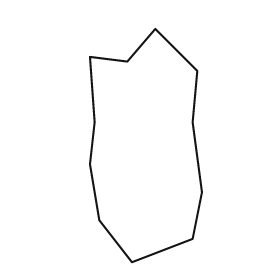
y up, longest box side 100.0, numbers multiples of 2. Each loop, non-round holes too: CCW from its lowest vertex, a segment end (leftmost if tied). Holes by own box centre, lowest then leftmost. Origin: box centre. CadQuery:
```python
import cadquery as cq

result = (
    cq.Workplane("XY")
    .moveTo(-6.0, -50.0)
    .lineTo(20.0, -40.0)
    .lineTo(24.0, -20.0)
    .lineTo(20.0, 10.0)
    .lineTo(22.0, 32.0)
    .lineTo(4.0, 50.0)
    .lineTo(-8.0, 36.0)
    .lineTo(-24.0, 38.0)
    .lineTo(-22.0, 10.0)
    .lineTo(-24.0, -8.0)
    .lineTo(-20.0, -32.0)
    .close()
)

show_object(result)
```